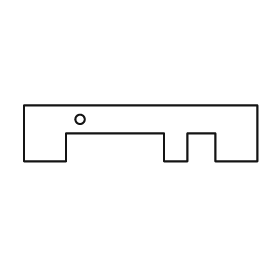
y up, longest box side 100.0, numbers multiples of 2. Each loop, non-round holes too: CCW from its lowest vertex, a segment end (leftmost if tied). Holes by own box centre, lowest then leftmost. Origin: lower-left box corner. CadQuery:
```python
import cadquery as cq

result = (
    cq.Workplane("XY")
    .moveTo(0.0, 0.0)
    .lineTo(18.0, 0.0)
    .lineTo(18.0, 12.0)
    .lineTo(60.0, 12.0)
    .lineTo(60.0, 0.0)
    .lineTo(70.0, 0.0)
    .lineTo(70.0, 12.0)
    .lineTo(82.0, 12.0)
    .lineTo(82.0, 0.0)
    .lineTo(100.0, 0.0)
    .lineTo(100.0, 24.0)
    .lineTo(0.0, 24.0)
    .close()
    .moveTo(24.0, 18.0)
    .circle(2.0)
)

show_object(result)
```